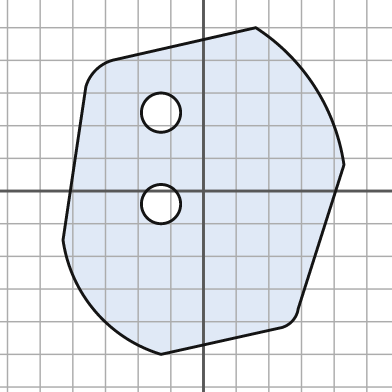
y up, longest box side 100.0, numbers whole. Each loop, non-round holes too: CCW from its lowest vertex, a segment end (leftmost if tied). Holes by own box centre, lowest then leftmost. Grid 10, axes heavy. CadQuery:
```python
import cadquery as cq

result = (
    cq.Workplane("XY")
    .moveTo(-13.0, -50.0)
    .lineTo(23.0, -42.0)
    .threePointArc((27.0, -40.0), (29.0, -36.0))
    .lineTo(43.0, 8.0)
    .threePointArc((34.0, 32.0), (16.0, 50.0))
    .lineTo(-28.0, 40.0)
    .threePointArc((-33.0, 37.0), (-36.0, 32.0))
    .lineTo(-43.0, -15.0)
    .threePointArc((-33.0, -37.0), (-13.0, -50.0))
    .close()
    .moveTo(-13.0, -4.0)
    .circle(6.0)
    .moveTo(-13.0, 24.0)
    .circle(6.0)
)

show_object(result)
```